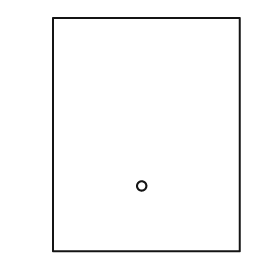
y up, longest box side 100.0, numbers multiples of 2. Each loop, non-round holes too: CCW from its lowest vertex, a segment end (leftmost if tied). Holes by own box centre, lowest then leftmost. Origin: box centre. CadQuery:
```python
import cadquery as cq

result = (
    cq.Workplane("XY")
    .moveTo(-40.0, -50.0)
    .lineTo(40.0, -50.0)
    .lineTo(40.0, 50.0)
    .lineTo(-40.0, 50.0)
    .close()
    .moveTo(-2.0, -22.0)
    .circle(2.0)
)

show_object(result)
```